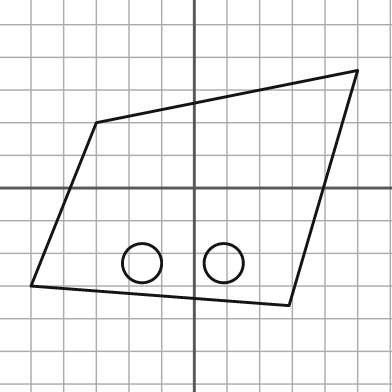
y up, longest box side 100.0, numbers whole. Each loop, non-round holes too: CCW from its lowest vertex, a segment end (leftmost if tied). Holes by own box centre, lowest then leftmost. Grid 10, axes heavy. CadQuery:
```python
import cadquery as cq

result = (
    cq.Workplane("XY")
    .moveTo(29.0, -36.0)
    .lineTo(50.0, 36.0)
    .lineTo(-30.0, 20.0)
    .lineTo(-50.0, -30.0)
    .close()
    .moveTo(-16.0, -23.0)
    .circle(6.0)
    .moveTo(9.0, -23.0)
    .circle(6.0)
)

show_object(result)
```